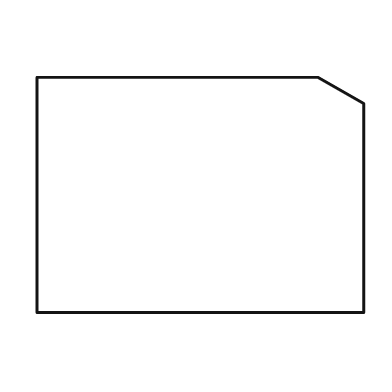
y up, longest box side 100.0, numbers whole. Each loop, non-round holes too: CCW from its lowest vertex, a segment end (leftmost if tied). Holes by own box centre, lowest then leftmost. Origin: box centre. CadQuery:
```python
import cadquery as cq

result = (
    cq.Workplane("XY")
    .moveTo(-50.0, -36.0)
    .lineTo(50.0, -36.0)
    .lineTo(50.0, 28.0)
    .lineTo(36.0, 36.0)
    .lineTo(-50.0, 36.0)
    .close()
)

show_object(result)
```